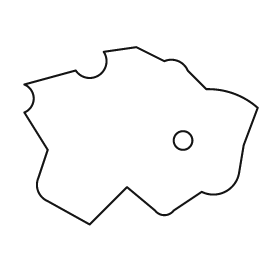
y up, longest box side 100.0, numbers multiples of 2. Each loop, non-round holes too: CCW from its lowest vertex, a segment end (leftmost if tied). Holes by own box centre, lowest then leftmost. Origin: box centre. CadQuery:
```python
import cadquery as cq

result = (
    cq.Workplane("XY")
    .moveTo(-22.0, -38.0)
    .lineTo(-6.0, -22.0)
    .lineTo(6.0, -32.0)
    .threePointArc((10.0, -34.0), (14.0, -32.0))
    .lineTo(26.0, -24.0)
    .threePointArc((36.0, -24.0), (42.0, -16.0))
    .lineTo(44.0, -4.0)
    .lineTo(50.0, 12.0)
    .threePointArc((40.0, 18.0), (28.0, 20.0))
    .lineTo(20.0, 28.0)
    .threePointArc((16.0, 32.0), (10.0, 32.0))
    .lineTo(-2.0, 38.0)
    .lineTo(-16.0, 36.0)
    .threePointArc((-18.0, 26.0), (-28.0, 28.0))
    .lineTo(-50.0, 22.0)
    .threePointArc((-46.0, 16.0), (-50.0, 10.0))
    .lineTo(-40.0, -6.0)
    .lineTo(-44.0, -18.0)
    .threePointArc((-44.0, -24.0), (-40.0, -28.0))
    .close()
    .moveTo(18.0, -2.0)
    .circle(4.0)
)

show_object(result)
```